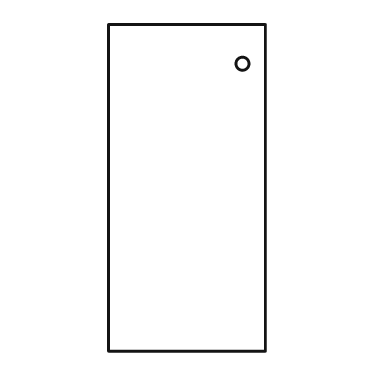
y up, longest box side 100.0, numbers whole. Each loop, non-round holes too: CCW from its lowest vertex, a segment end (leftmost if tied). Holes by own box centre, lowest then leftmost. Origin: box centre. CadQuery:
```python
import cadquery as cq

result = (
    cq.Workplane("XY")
    .moveTo(-24.0, -50.0)
    .lineTo(24.0, -50.0)
    .lineTo(24.0, 50.0)
    .lineTo(-24.0, 50.0)
    .close()
    .moveTo(17.0, 38.0)
    .circle(2.0)
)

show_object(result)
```